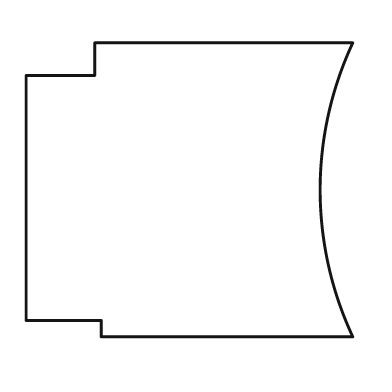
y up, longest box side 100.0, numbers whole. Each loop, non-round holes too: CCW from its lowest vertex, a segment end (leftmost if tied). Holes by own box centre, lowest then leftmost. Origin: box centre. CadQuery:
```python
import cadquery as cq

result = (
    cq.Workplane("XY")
    .moveTo(-27.0, -45.0)
    .lineTo(50.0, -45.0)
    .threePointArc((40.0, 0.0), (50.0, 45.0))
    .lineTo(-29.0, 45.0)
    .lineTo(-29.0, 35.0)
    .lineTo(-50.0, 35.0)
    .lineTo(-50.0, -40.0)
    .lineTo(-27.0, -40.0)
    .close()
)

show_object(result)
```